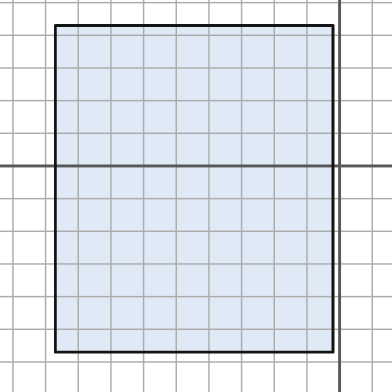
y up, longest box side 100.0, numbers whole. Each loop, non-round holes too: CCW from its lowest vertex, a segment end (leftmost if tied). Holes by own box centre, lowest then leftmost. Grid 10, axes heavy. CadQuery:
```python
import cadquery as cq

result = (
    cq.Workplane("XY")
    .moveTo(-87.0, -57.0)
    .lineTo(-2.0, -57.0)
    .lineTo(-2.0, 43.0)
    .lineTo(-87.0, 43.0)
    .close()
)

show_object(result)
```